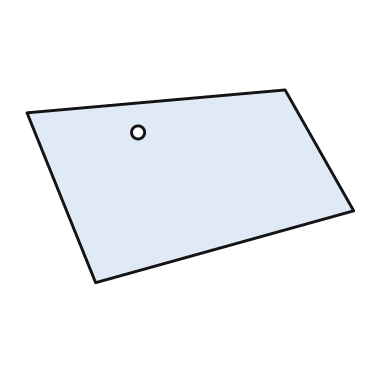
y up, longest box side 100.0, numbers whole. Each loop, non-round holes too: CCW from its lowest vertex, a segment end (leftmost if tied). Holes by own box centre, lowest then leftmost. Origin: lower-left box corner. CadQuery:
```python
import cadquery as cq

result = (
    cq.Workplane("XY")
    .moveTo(21.0, 0.0)
    .lineTo(100.0, 22.0)
    .lineTo(79.0, 59.0)
    .lineTo(0.0, 52.0)
    .close()
    .moveTo(34.0, 46.0)
    .circle(2.0)
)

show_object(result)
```